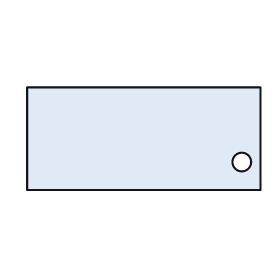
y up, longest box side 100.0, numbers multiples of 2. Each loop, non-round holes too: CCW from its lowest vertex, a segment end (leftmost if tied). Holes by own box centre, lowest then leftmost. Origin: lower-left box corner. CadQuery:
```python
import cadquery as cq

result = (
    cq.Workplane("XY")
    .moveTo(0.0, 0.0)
    .lineTo(100.0, 0.0)
    .lineTo(100.0, 44.0)
    .lineTo(0.0, 44.0)
    .close()
    .moveTo(92.0, 12.0)
    .circle(4.0)
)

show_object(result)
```